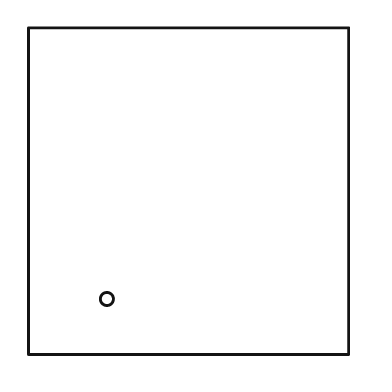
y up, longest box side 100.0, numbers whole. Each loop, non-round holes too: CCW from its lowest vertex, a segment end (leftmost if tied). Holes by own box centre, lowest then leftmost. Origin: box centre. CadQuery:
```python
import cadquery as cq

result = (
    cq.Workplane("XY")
    .moveTo(-49.0, -50.0)
    .lineTo(49.0, -50.0)
    .lineTo(49.0, 50.0)
    .lineTo(-49.0, 50.0)
    .close()
    .moveTo(-25.0, -33.0)
    .circle(2.0)
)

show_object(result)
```